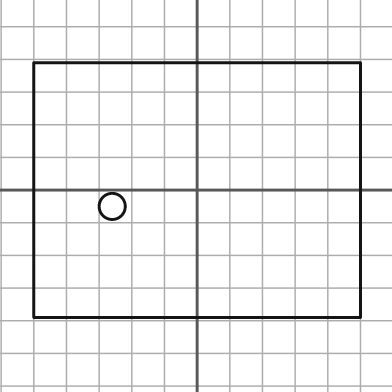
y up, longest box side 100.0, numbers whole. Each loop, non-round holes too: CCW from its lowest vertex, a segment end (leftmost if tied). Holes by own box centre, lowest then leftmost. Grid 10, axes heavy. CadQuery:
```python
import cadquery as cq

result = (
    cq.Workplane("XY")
    .moveTo(-50.0, -39.0)
    .lineTo(50.0, -39.0)
    .lineTo(50.0, 39.0)
    .lineTo(-50.0, 39.0)
    .close()
    .moveTo(-26.0, -5.0)
    .circle(4.0)
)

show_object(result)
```